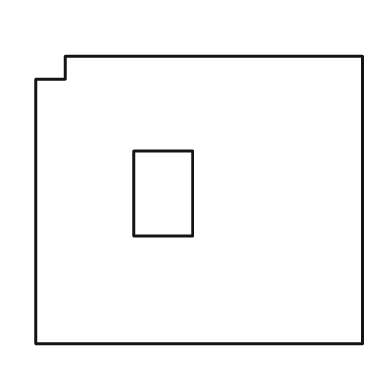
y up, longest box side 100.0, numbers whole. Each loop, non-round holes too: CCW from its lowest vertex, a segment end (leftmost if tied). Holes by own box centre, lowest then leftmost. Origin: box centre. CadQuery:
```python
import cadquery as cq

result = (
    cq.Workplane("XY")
    .moveTo(-50.0, -44.0)
    .lineTo(50.0, -44.0)
    .lineTo(50.0, 44.0)
    .lineTo(-41.0, 44.0)
    .lineTo(-41.0, 37.0)
    .lineTo(-50.0, 37.0)
    .close()
    .moveTo(-20.0, -11.0)
    .lineTo(-2.0, -11.0)
    .lineTo(-2.0, 15.0)
    .lineTo(-20.0, 15.0)
    .close()
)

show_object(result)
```